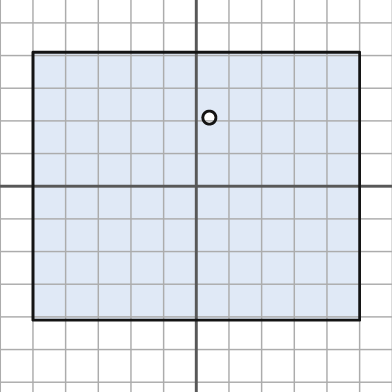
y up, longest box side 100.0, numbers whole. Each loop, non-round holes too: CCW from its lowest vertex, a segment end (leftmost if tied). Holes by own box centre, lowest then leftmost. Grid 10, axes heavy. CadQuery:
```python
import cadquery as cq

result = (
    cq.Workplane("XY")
    .moveTo(-50.0, -41.0)
    .lineTo(50.0, -41.0)
    .lineTo(50.0, 41.0)
    .lineTo(-50.0, 41.0)
    .close()
    .moveTo(4.0, 21.0)
    .circle(2.0)
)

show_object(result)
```